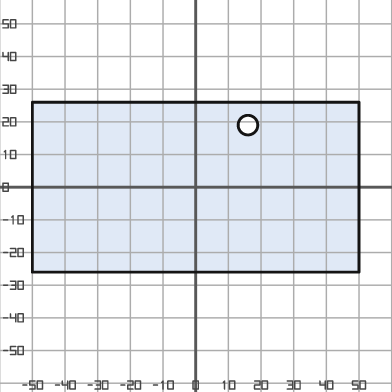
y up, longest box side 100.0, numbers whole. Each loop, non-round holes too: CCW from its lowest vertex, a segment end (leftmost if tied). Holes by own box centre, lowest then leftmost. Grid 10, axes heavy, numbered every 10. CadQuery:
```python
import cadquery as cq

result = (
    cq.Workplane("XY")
    .moveTo(-50.0, -26.0)
    .lineTo(50.0, -26.0)
    .lineTo(50.0, 26.0)
    .lineTo(-50.0, 26.0)
    .close()
    .moveTo(16.0, 19.0)
    .circle(3.0)
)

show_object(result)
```